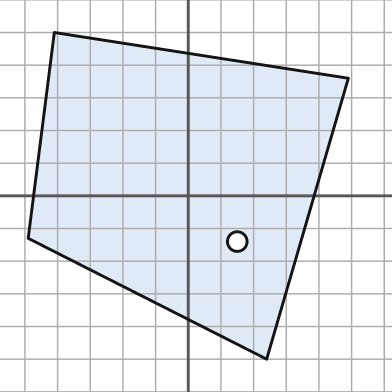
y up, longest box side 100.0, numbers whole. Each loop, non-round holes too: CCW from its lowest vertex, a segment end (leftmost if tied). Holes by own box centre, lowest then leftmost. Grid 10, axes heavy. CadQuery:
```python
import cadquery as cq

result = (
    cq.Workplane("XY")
    .moveTo(24.0, -50.0)
    .lineTo(49.0, 36.0)
    .lineTo(-41.0, 50.0)
    .lineTo(-49.0, -13.0)
    .close()
    .moveTo(15.0, -14.0)
    .circle(3.0)
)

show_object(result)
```